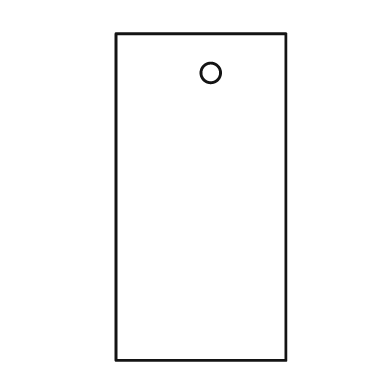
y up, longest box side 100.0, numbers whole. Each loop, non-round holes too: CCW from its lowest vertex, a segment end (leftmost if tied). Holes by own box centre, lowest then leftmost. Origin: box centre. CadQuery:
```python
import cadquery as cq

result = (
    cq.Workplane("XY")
    .moveTo(-26.0, -50.0)
    .lineTo(26.0, -50.0)
    .lineTo(26.0, 50.0)
    .lineTo(-26.0, 50.0)
    .close()
    .moveTo(3.0, 38.0)
    .circle(3.0)
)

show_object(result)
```